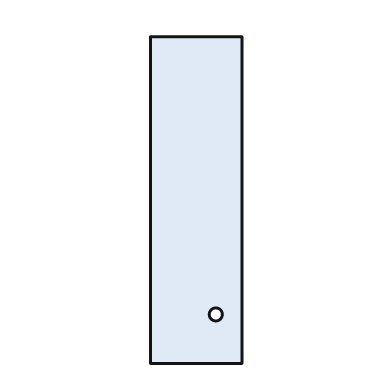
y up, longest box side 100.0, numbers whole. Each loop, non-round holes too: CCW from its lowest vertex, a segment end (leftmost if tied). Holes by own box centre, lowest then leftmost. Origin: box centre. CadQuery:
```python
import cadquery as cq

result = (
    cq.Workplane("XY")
    .moveTo(-14.0, -50.0)
    .lineTo(14.0, -50.0)
    .lineTo(14.0, 50.0)
    .lineTo(-14.0, 50.0)
    .close()
    .moveTo(6.0, -35.0)
    .circle(2.0)
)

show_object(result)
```